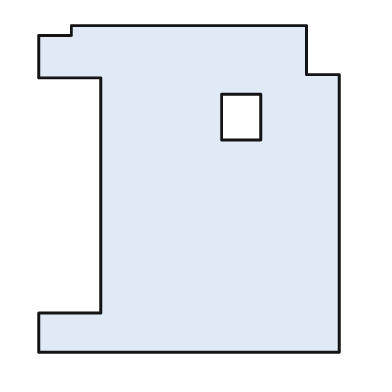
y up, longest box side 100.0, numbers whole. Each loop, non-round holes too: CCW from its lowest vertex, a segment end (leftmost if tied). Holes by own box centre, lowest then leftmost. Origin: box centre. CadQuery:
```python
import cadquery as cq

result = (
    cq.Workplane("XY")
    .moveTo(-46.0, -50.0)
    .lineTo(46.0, -50.0)
    .lineTo(46.0, 35.0)
    .lineTo(36.0, 35.0)
    .lineTo(36.0, 50.0)
    .lineTo(-36.0, 50.0)
    .lineTo(-36.0, 47.0)
    .lineTo(-46.0, 47.0)
    .lineTo(-46.0, 34.0)
    .lineTo(-27.0, 34.0)
    .lineTo(-27.0, -38.0)
    .lineTo(-46.0, -38.0)
    .close()
    .moveTo(10.0, 15.0)
    .lineTo(22.0, 15.0)
    .lineTo(22.0, 29.0)
    .lineTo(10.0, 29.0)
    .close()
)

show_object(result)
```